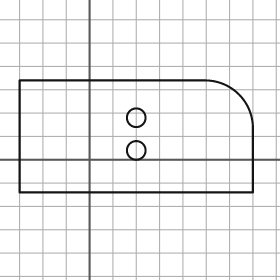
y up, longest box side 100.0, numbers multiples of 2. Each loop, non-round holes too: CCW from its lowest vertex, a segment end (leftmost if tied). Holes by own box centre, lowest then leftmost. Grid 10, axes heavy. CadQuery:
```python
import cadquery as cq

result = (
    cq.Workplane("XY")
    .moveTo(-30.0, -14.0)
    .lineTo(70.0, -14.0)
    .lineTo(70.0, 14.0)
    .threePointArc((64.0, 28.0), (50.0, 34.0))
    .lineTo(-30.0, 34.0)
    .close()
    .moveTo(20.0, 4.0)
    .circle(4.0)
    .moveTo(20.0, 18.0)
    .circle(4.0)
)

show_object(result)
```